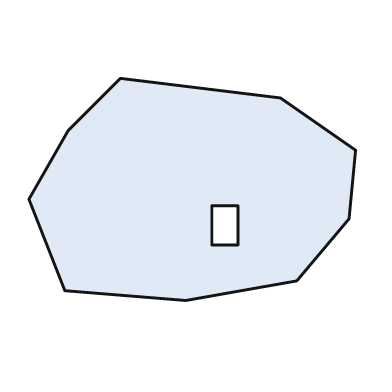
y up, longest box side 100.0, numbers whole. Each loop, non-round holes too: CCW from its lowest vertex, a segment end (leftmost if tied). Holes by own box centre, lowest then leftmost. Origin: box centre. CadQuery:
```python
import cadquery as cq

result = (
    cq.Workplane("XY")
    .moveTo(-2.0, -34.0)
    .lineTo(32.0, -28.0)
    .lineTo(48.0, -9.0)
    .lineTo(50.0, 12.0)
    .lineTo(27.0, 28.0)
    .lineTo(-22.0, 34.0)
    .lineTo(-38.0, 18.0)
    .lineTo(-50.0, -3.0)
    .lineTo(-39.0, -31.0)
    .close()
    .moveTo(6.0, -17.0)
    .lineTo(14.0, -17.0)
    .lineTo(14.0, -5.0)
    .lineTo(6.0, -5.0)
    .close()
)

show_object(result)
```